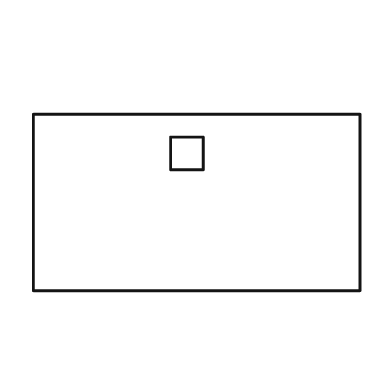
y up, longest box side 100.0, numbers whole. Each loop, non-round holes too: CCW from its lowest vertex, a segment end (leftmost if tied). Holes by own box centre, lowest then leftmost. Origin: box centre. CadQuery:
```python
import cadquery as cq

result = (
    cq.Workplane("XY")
    .moveTo(-50.0, -27.0)
    .lineTo(50.0, -27.0)
    .lineTo(50.0, 27.0)
    .lineTo(-50.0, 27.0)
    .close()
    .moveTo(-8.0, 10.0)
    .lineTo(2.0, 10.0)
    .lineTo(2.0, 20.0)
    .lineTo(-8.0, 20.0)
    .close()
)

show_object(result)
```